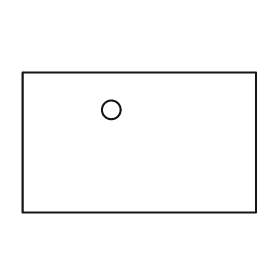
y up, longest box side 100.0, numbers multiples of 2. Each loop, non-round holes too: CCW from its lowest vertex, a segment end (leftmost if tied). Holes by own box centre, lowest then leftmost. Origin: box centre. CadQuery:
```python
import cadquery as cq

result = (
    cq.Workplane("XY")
    .moveTo(-50.0, -30.0)
    .lineTo(50.0, -30.0)
    .lineTo(50.0, 30.0)
    .lineTo(-50.0, 30.0)
    .close()
    .moveTo(-12.0, 14.0)
    .circle(4.0)
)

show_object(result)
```